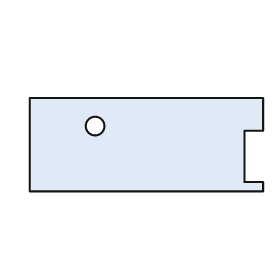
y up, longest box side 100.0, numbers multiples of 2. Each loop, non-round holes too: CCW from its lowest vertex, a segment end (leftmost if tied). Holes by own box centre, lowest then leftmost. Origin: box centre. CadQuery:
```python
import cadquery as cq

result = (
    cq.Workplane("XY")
    .moveTo(-50.0, -20.0)
    .lineTo(50.0, -20.0)
    .lineTo(50.0, -16.0)
    .lineTo(42.0, -16.0)
    .lineTo(42.0, 6.0)
    .lineTo(50.0, 6.0)
    .lineTo(50.0, 20.0)
    .lineTo(-50.0, 20.0)
    .close()
    .moveTo(-22.0, 8.0)
    .circle(4.0)
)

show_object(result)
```